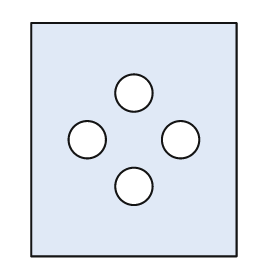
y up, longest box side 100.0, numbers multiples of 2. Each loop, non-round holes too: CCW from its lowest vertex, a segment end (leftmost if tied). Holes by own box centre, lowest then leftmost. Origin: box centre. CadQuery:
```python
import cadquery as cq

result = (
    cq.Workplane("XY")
    .moveTo(-44.0, -50.0)
    .lineTo(44.0, -50.0)
    .lineTo(44.0, 50.0)
    .lineTo(-44.0, 50.0)
    .close()
    .moveTo(0.0, -20.0)
    .circle(8.0)
    .moveTo(-20.0, 0.0)
    .circle(8.0)
    .moveTo(20.0, 0.0)
    .circle(8.0)
    .moveTo(0.0, 20.0)
    .circle(8.0)
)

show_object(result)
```